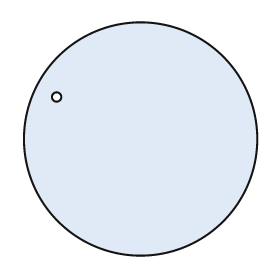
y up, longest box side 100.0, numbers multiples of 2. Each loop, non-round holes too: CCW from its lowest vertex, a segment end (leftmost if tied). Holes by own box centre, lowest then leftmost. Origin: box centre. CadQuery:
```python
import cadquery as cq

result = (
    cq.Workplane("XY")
    .moveTo(0.0, 0.0)
    .circle(50.0)
    .moveTo(-36.0, 18.0)
    .circle(2.0)
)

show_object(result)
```